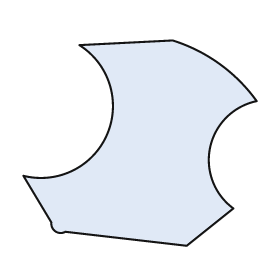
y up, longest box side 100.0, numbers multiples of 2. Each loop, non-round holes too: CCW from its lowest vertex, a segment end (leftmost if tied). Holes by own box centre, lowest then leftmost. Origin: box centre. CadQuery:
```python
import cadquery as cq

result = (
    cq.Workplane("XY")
    .moveTo(20.0, -44.0)
    .lineTo(40.0, -28.0)
    .threePointArc((30.0, -2.0), (50.0, 18.0))
    .threePointArc((34.0, 34.0), (14.0, 44.0))
    .lineTo(-26.0, 42.0)
    .threePointArc((-14.0, 4.0), (-50.0, -14.0))
    .lineTo(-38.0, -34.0)
    .threePointArc((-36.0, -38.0), (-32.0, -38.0))
    .close()
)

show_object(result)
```